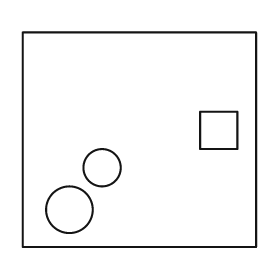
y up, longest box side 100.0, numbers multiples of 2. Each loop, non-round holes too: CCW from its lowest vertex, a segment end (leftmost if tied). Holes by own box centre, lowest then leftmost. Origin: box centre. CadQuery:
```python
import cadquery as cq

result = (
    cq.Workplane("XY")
    .moveTo(-50.0, -46.0)
    .lineTo(50.0, -46.0)
    .lineTo(50.0, 46.0)
    .lineTo(-50.0, 46.0)
    .close()
    .moveTo(-30.0, -30.0)
    .circle(10.0)
    .moveTo(-16.0, -12.0)
    .circle(8.0)
    .moveTo(26.0, -4.0)
    .lineTo(42.0, -4.0)
    .lineTo(42.0, 12.0)
    .lineTo(26.0, 12.0)
    .close()
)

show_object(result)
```